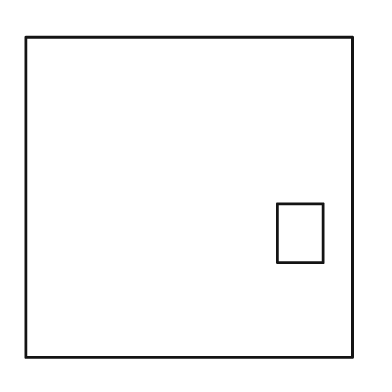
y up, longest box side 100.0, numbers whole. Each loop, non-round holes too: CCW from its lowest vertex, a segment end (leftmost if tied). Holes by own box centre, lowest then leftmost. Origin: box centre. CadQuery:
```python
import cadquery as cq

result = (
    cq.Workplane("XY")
    .moveTo(-50.0, -49.0)
    .lineTo(50.0, -49.0)
    .lineTo(50.0, 49.0)
    .lineTo(-50.0, 49.0)
    .close()
    .moveTo(27.0, -20.0)
    .lineTo(41.0, -20.0)
    .lineTo(41.0, -2.0)
    .lineTo(27.0, -2.0)
    .close()
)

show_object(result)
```